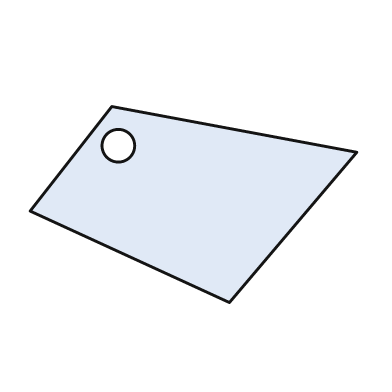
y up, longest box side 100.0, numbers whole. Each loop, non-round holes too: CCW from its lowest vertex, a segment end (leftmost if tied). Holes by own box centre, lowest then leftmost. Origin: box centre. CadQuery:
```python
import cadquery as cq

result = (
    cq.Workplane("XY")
    .moveTo(11.0, -30.0)
    .lineTo(50.0, 16.0)
    .lineTo(-25.0, 30.0)
    .lineTo(-50.0, -2.0)
    .close()
    .moveTo(-23.0, 18.0)
    .circle(5.0)
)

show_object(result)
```